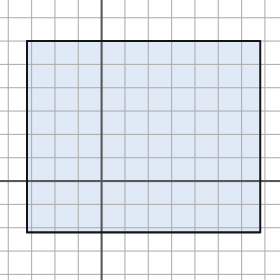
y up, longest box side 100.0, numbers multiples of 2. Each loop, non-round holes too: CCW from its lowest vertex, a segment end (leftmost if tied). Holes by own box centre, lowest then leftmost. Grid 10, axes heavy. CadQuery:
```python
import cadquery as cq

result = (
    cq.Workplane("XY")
    .moveTo(-32.0, -22.0)
    .lineTo(68.0, -22.0)
    .lineTo(68.0, 60.0)
    .lineTo(-32.0, 60.0)
    .close()
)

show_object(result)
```